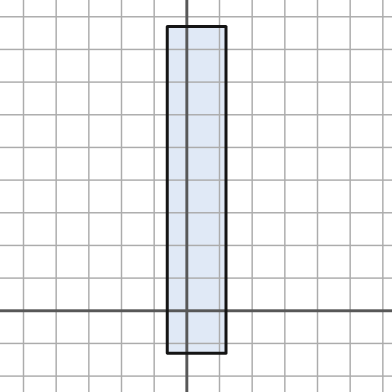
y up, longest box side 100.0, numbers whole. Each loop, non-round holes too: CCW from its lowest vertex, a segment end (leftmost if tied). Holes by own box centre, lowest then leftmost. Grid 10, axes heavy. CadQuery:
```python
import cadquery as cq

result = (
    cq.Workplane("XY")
    .moveTo(-6.0, -13.0)
    .lineTo(12.0, -13.0)
    .lineTo(12.0, 87.0)
    .lineTo(-6.0, 87.0)
    .close()
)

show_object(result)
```